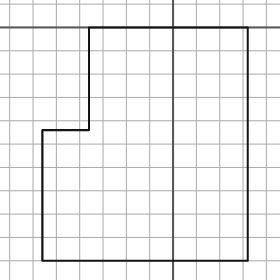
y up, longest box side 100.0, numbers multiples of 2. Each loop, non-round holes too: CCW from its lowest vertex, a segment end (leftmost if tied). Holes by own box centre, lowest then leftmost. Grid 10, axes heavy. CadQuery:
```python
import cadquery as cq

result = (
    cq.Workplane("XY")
    .moveTo(-56.0, -100.0)
    .lineTo(32.0, -100.0)
    .lineTo(32.0, 0.0)
    .lineTo(-36.0, 0.0)
    .lineTo(-36.0, -44.0)
    .lineTo(-56.0, -44.0)
    .close()
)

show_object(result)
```